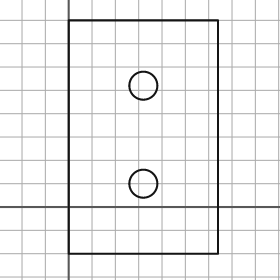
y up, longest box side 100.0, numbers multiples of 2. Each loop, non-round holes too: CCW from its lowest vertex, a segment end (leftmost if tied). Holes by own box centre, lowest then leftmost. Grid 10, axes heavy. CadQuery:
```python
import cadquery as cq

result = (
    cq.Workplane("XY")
    .moveTo(0.0, -20.0)
    .lineTo(64.0, -20.0)
    .lineTo(64.0, 80.0)
    .lineTo(0.0, 80.0)
    .close()
    .moveTo(32.0, 10.0)
    .circle(6.0)
    .moveTo(32.0, 52.0)
    .circle(6.0)
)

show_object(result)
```